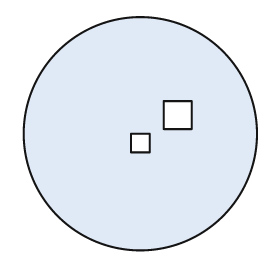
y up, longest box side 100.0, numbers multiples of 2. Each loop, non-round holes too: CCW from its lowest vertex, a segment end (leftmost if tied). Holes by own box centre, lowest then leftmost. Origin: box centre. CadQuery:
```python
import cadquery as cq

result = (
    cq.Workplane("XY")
    .moveTo(0.0, 0.0)
    .circle(50.0)
    .moveTo(-4.0, -8.0)
    .lineTo(4.0, -8.0)
    .lineTo(4.0, 0.0)
    .lineTo(-4.0, 0.0)
    .close()
    .moveTo(10.0, 2.0)
    .lineTo(22.0, 2.0)
    .lineTo(22.0, 14.0)
    .lineTo(10.0, 14.0)
    .close()
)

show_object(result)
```